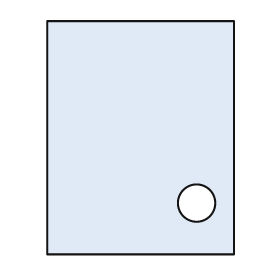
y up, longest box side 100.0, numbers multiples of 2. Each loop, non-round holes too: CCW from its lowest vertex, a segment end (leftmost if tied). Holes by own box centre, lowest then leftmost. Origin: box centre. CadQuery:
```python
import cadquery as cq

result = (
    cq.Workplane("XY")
    .moveTo(-40.0, -50.0)
    .lineTo(40.0, -50.0)
    .lineTo(40.0, 50.0)
    .lineTo(-40.0, 50.0)
    .close()
    .moveTo(24.0, -28.0)
    .circle(8.0)
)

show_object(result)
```